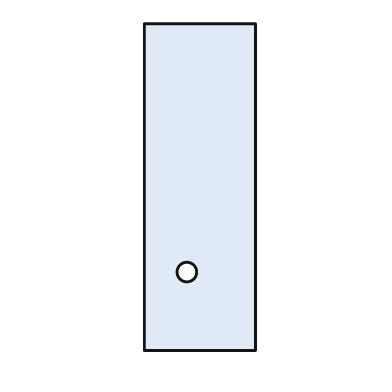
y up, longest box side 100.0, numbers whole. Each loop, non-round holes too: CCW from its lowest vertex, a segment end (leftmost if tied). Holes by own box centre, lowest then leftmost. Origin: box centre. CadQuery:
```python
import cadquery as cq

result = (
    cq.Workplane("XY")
    .moveTo(-17.0, -50.0)
    .lineTo(17.0, -50.0)
    .lineTo(17.0, 50.0)
    .lineTo(-17.0, 50.0)
    .close()
    .moveTo(-4.0, -26.0)
    .circle(3.0)
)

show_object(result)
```